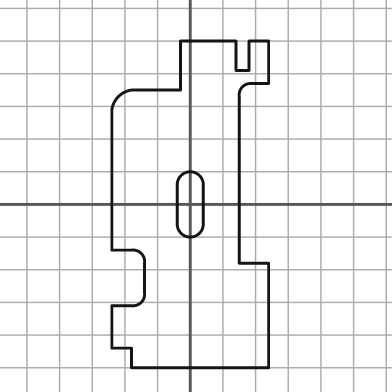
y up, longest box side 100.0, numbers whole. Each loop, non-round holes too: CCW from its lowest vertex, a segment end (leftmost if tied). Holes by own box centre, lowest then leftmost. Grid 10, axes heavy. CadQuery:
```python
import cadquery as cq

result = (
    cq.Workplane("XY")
    .moveTo(-18.0, -50.0)
    .lineTo(24.0, -50.0)
    .lineTo(24.0, -18.0)
    .lineTo(15.0, -18.0)
    .lineTo(15.0, 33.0)
    .threePointArc((16.0, 36.0), (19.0, 37.0))
    .lineTo(24.0, 37.0)
    .lineTo(24.0, 50.0)
    .lineTo(18.0, 50.0)
    .lineTo(18.0, 41.0)
    .lineTo(14.0, 41.0)
    .lineTo(14.0, 50.0)
    .lineTo(-3.0, 50.0)
    .lineTo(-3.0, 35.0)
    .lineTo(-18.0, 35.0)
    .threePointArc((-22.0, 33.0), (-24.0, 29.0))
    .lineTo(-24.0, -14.0)
    .lineTo(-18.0, -14.0)
    .threePointArc((-15.0, -15.0), (-14.0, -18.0))
    .lineTo(-14.0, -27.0)
    .threePointArc((-15.0, -30.0), (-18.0, -31.0))
    .lineTo(-24.0, -31.0)
    .lineTo(-24.0, -44.0)
    .lineTo(-18.0, -44.0)
    .close()
    .moveTo(-4.0, -6.0)
    .threePointArc((0.0, -10.0), (4.0, -6.0))
    .lineTo(4.0, 6.0)
    .threePointArc((0.0, 10.0), (-4.0, 6.0))
    .close()
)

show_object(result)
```